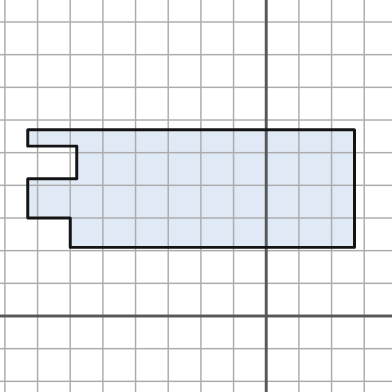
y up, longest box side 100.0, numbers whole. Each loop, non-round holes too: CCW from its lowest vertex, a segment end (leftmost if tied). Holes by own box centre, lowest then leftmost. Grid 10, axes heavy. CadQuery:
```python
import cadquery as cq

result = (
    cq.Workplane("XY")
    .moveTo(-60.0, 21.0)
    .lineTo(27.0, 21.0)
    .lineTo(27.0, 57.0)
    .lineTo(-73.0, 57.0)
    .lineTo(-73.0, 52.0)
    .lineTo(-58.0, 52.0)
    .lineTo(-58.0, 42.0)
    .lineTo(-73.0, 42.0)
    .lineTo(-73.0, 30.0)
    .lineTo(-60.0, 30.0)
    .close()
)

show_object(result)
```